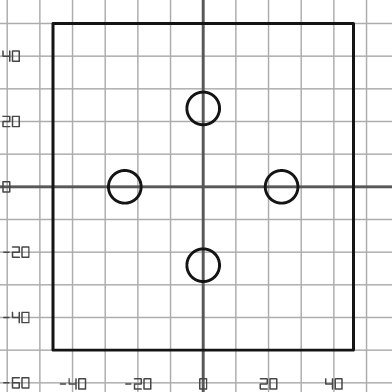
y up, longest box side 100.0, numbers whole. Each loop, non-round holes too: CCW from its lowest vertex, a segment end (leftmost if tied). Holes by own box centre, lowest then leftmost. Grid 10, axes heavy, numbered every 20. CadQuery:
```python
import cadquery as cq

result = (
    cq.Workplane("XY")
    .moveTo(-46.0, -50.0)
    .lineTo(46.0, -50.0)
    .lineTo(46.0, 50.0)
    .lineTo(-46.0, 50.0)
    .close()
    .moveTo(0.0, -24.0)
    .circle(5.0)
    .moveTo(-24.0, 0.0)
    .circle(5.0)
    .moveTo(24.0, 0.0)
    .circle(5.0)
    .moveTo(0.0, 24.0)
    .circle(5.0)
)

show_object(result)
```